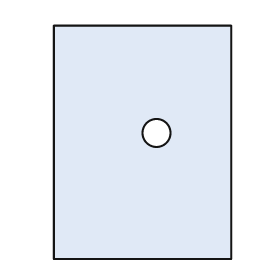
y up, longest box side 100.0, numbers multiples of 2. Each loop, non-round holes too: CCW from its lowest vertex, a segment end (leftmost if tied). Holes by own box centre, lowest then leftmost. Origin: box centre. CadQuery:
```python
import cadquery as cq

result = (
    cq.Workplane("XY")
    .moveTo(-38.0, -50.0)
    .lineTo(38.0, -50.0)
    .lineTo(38.0, 50.0)
    .lineTo(-38.0, 50.0)
    .close()
    .moveTo(6.0, 4.0)
    .circle(6.0)
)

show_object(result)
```